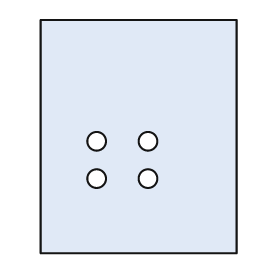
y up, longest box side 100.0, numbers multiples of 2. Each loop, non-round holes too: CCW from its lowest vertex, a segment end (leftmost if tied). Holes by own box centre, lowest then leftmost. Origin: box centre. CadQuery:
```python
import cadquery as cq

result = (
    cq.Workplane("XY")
    .moveTo(-42.0, -50.0)
    .lineTo(42.0, -50.0)
    .lineTo(42.0, 50.0)
    .lineTo(-42.0, 50.0)
    .close()
    .moveTo(-18.0, -18.0)
    .circle(4.0)
    .moveTo(4.0, -18.0)
    .circle(4.0)
    .moveTo(-18.0, -2.0)
    .circle(4.0)
    .moveTo(4.0, -2.0)
    .circle(4.0)
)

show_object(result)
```